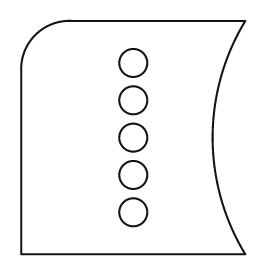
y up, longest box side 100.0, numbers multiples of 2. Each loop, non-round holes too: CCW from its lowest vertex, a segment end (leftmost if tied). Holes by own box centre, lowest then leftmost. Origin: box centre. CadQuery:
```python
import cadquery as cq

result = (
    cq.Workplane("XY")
    .moveTo(-48.0, -50.0)
    .lineTo(48.0, -50.0)
    .threePointArc((34.0, 0.0), (48.0, 50.0))
    .lineTo(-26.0, 50.0)
    .threePointArc((-42.0, 44.0), (-48.0, 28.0))
    .close()
    .moveTo(0.0, -32.0)
    .circle(6.0)
    .moveTo(0.0, -16.0)
    .circle(6.0)
    .moveTo(0.0, 0.0)
    .circle(6.0)
    .moveTo(0.0, 16.0)
    .circle(6.0)
    .moveTo(0.0, 32.0)
    .circle(6.0)
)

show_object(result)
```